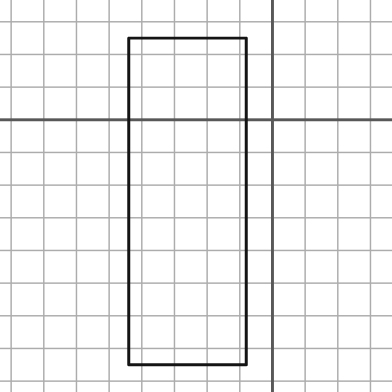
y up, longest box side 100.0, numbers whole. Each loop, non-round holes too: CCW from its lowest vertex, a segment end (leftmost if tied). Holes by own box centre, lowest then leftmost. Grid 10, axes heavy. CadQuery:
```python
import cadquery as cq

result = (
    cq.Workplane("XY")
    .moveTo(-44.0, -75.0)
    .lineTo(-8.0, -75.0)
    .lineTo(-8.0, 25.0)
    .lineTo(-44.0, 25.0)
    .close()
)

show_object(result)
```